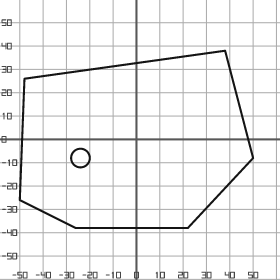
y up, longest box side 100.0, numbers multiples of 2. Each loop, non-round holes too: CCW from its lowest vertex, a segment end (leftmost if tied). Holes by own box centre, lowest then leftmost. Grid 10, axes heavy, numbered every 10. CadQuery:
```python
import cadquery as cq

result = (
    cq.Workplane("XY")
    .moveTo(-26.0, -38.0)
    .lineTo(22.0, -38.0)
    .lineTo(50.0, -8.0)
    .lineTo(38.0, 38.0)
    .lineTo(-48.0, 26.0)
    .lineTo(-50.0, -26.0)
    .close()
    .moveTo(-24.0, -8.0)
    .circle(4.0)
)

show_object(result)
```